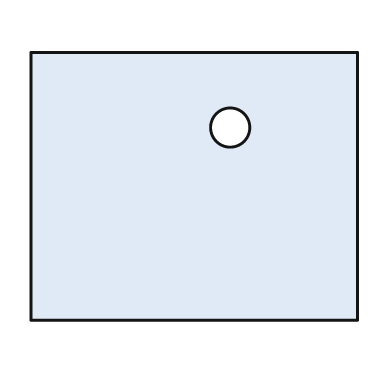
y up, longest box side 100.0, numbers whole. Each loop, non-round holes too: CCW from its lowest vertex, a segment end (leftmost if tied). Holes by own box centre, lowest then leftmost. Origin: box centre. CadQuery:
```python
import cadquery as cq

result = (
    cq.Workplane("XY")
    .moveTo(-50.0, -41.0)
    .lineTo(50.0, -41.0)
    .lineTo(50.0, 41.0)
    .lineTo(-50.0, 41.0)
    .close()
    .moveTo(11.0, 18.0)
    .circle(6.0)
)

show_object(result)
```